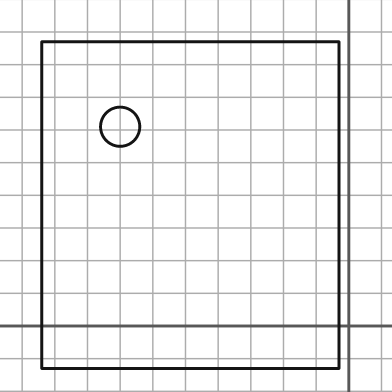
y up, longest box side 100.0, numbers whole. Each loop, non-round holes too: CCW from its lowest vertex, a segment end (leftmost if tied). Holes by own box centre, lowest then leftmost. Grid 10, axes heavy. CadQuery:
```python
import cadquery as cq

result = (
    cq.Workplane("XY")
    .moveTo(-94.0, -13.0)
    .lineTo(-3.0, -13.0)
    .lineTo(-3.0, 87.0)
    .lineTo(-94.0, 87.0)
    .close()
    .moveTo(-70.0, 61.0)
    .circle(6.0)
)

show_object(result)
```